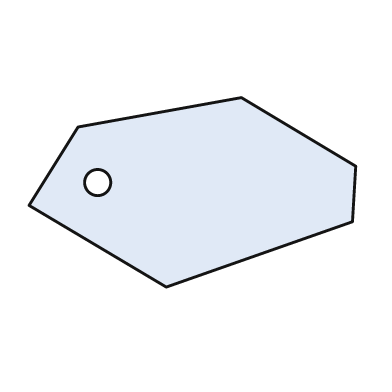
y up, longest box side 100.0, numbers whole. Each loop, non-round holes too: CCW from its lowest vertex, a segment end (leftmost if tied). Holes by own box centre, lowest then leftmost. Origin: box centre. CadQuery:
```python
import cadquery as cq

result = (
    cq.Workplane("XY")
    .moveTo(-8.0, -29.0)
    .lineTo(49.0, -9.0)
    .lineTo(50.0, 8.0)
    .lineTo(15.0, 29.0)
    .lineTo(-35.0, 20.0)
    .lineTo(-50.0, -4.0)
    .close()
    .moveTo(-29.0, 3.0)
    .circle(4.0)
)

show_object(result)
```